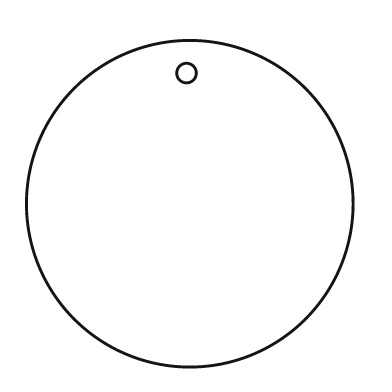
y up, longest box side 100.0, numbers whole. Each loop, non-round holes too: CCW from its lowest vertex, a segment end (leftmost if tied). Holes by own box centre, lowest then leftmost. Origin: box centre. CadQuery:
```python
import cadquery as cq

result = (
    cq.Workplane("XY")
    .moveTo(0.0, 0.0)
    .circle(50.0)
    .moveTo(-1.0, 40.0)
    .circle(3.0)
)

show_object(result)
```